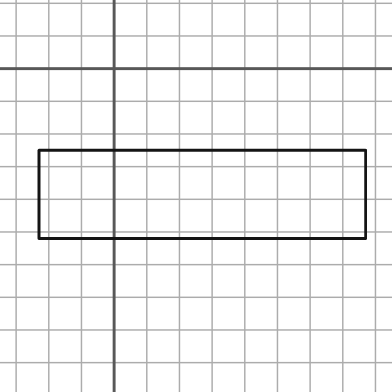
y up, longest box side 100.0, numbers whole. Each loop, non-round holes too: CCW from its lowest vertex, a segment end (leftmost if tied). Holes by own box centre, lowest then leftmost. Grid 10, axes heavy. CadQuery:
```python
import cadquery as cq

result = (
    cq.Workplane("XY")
    .moveTo(-23.0, -52.0)
    .lineTo(77.0, -52.0)
    .lineTo(77.0, -25.0)
    .lineTo(-23.0, -25.0)
    .close()
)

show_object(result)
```